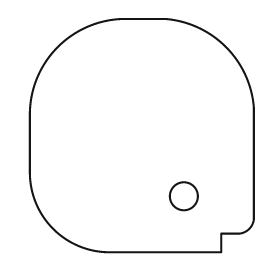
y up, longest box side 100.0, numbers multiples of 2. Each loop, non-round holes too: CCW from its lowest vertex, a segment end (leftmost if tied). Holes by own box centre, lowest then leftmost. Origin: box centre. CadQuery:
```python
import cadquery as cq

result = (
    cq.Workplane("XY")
    .moveTo(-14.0, -50.0)
    .lineTo(34.0, -50.0)
    .lineTo(34.0, -42.0)
    .lineTo(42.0, -42.0)
    .threePointArc((46.0, -40.0), (48.0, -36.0))
    .lineTo(48.0, 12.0)
    .threePointArc((36.0, 38.0), (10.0, 50.0))
    .lineTo(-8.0, 50.0)
    .threePointArc((-36.0, 38.0), (-48.0, 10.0))
    .lineTo(-48.0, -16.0)
    .threePointArc((-38.0, -40.0), (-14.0, -50.0))
    .close()
    .moveTo(18.0, -26.0)
    .circle(6.0)
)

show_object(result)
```